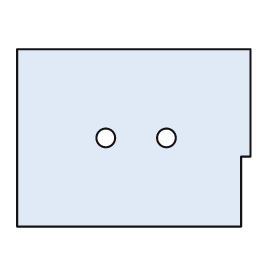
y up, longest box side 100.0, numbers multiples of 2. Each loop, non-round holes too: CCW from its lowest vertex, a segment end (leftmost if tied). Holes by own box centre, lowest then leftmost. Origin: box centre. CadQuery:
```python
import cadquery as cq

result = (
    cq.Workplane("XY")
    .moveTo(-50.0, -38.0)
    .lineTo(46.0, -38.0)
    .lineTo(46.0, -8.0)
    .lineTo(50.0, -8.0)
    .lineTo(50.0, 38.0)
    .lineTo(-50.0, 38.0)
    .close()
    .moveTo(-12.0, 0.0)
    .circle(4.0)
    .moveTo(14.0, 0.0)
    .circle(4.0)
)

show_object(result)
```